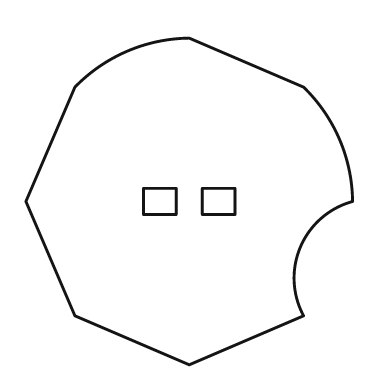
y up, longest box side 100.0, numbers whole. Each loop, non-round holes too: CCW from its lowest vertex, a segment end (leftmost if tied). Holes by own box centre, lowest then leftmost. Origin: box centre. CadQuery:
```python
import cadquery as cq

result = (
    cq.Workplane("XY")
    .moveTo(0.0, -50.0)
    .lineTo(35.0, -35.0)
    .threePointArc((34.0, -14.0), (50.0, 0.0))
    .threePointArc((46.0, 19.0), (35.0, 35.0))
    .lineTo(0.0, 50.0)
    .threePointArc((-19.0, 46.0), (-35.0, 35.0))
    .lineTo(-50.0, 0.0)
    .lineTo(-35.0, -35.0)
    .close()
    .moveTo(-14.0, -4.0)
    .lineTo(-4.0, -4.0)
    .lineTo(-4.0, 4.0)
    .lineTo(-14.0, 4.0)
    .close()
    .moveTo(4.0, -4.0)
    .lineTo(14.0, -4.0)
    .lineTo(14.0, 4.0)
    .lineTo(4.0, 4.0)
    .close()
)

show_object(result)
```